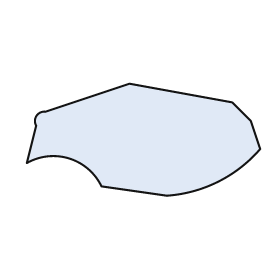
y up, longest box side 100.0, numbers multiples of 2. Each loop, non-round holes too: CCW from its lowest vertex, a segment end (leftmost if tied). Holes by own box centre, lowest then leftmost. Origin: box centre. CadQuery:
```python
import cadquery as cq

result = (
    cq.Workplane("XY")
    .moveTo(10.0, -24.0)
    .threePointArc((32.0, -18.0), (50.0, -4.0))
    .lineTo(46.0, 8.0)
    .lineTo(38.0, 16.0)
    .lineTo(-6.0, 24.0)
    .lineTo(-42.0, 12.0)
    .threePointArc((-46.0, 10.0), (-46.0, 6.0))
    .lineTo(-50.0, -10.0)
    .threePointArc((-32.0, -8.0), (-18.0, -20.0))
    .close()
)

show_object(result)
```